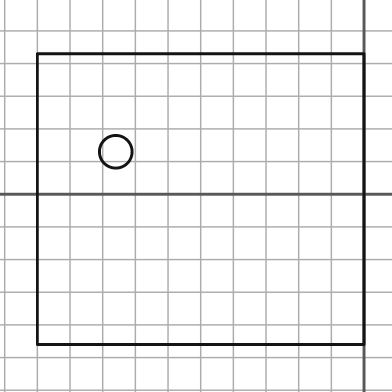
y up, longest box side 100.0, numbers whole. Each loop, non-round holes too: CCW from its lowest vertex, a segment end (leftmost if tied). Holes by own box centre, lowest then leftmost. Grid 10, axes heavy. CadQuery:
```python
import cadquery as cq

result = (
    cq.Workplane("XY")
    .moveTo(-100.0, -46.0)
    .lineTo(0.0, -46.0)
    .lineTo(0.0, 43.0)
    .lineTo(-100.0, 43.0)
    .close()
    .moveTo(-76.0, 13.0)
    .circle(5.0)
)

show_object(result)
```